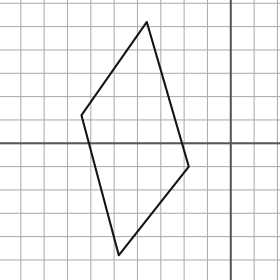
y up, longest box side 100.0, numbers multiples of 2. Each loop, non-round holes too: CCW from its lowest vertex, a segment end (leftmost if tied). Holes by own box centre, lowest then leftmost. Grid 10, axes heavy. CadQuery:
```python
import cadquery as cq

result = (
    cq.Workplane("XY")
    .moveTo(-48.0, -48.0)
    .lineTo(-18.0, -10.0)
    .lineTo(-36.0, 52.0)
    .lineTo(-64.0, 12.0)
    .close()
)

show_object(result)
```